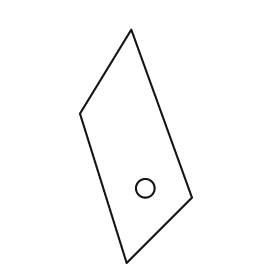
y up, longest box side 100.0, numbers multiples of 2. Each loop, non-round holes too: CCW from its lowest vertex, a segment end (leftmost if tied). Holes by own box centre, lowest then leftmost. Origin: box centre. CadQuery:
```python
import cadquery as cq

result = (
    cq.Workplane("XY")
    .moveTo(-4.0, -50.0)
    .lineTo(24.0, -22.0)
    .lineTo(-2.0, 50.0)
    .lineTo(-24.0, 14.0)
    .close()
    .moveTo(4.0, -18.0)
    .circle(4.0)
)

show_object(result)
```